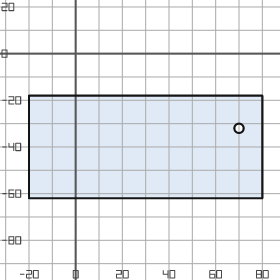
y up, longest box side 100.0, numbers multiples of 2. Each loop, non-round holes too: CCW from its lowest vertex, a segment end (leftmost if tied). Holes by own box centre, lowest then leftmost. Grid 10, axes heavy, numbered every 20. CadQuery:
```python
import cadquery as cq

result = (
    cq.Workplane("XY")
    .moveTo(-20.0, -62.0)
    .lineTo(80.0, -62.0)
    .lineTo(80.0, -18.0)
    .lineTo(-20.0, -18.0)
    .close()
    .moveTo(70.0, -32.0)
    .circle(2.0)
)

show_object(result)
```